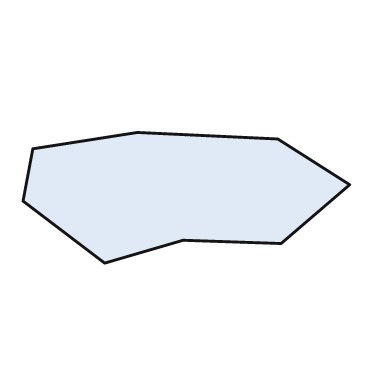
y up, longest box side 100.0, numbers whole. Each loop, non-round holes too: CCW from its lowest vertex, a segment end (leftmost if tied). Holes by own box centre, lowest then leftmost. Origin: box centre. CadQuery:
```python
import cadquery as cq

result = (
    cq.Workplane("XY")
    .moveTo(-25.0, -20.0)
    .lineTo(-1.0, -13.0)
    .lineTo(29.0, -14.0)
    .lineTo(50.0, 4.0)
    .lineTo(28.0, 18.0)
    .lineTo(-15.0, 20.0)
    .lineTo(-47.0, 15.0)
    .lineTo(-50.0, -1.0)
    .close()
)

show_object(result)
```